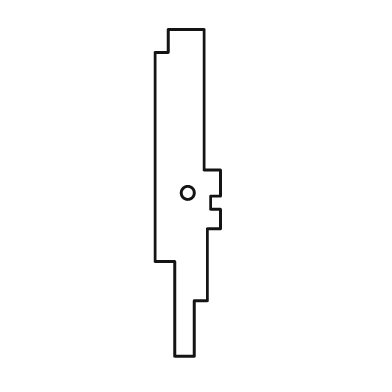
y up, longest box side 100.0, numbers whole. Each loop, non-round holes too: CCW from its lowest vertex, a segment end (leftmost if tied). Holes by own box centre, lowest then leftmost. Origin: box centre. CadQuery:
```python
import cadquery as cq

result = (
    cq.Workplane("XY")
    .moveTo(-4.0, -50.0)
    .lineTo(2.0, -50.0)
    .lineTo(2.0, -33.0)
    .lineTo(6.0, -33.0)
    .lineTo(6.0, -11.0)
    .lineTo(10.0, -11.0)
    .lineTo(10.0, -5.0)
    .lineTo(7.0, -5.0)
    .lineTo(7.0, -1.0)
    .lineTo(10.0, -1.0)
    .lineTo(10.0, 7.0)
    .lineTo(5.0, 7.0)
    .lineTo(5.0, 50.0)
    .lineTo(-6.0, 50.0)
    .lineTo(-6.0, 43.0)
    .lineTo(-10.0, 43.0)
    .lineTo(-10.0, -21.0)
    .lineTo(-4.0, -21.0)
    .close()
    .moveTo(0.0, 0.0)
    .circle(2.0)
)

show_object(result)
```